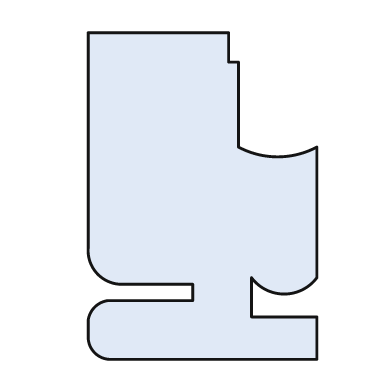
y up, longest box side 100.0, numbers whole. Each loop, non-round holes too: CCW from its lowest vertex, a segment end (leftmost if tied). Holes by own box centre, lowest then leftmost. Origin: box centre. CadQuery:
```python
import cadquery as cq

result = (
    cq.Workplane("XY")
    .moveTo(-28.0, -50.0)
    .lineTo(35.0, -50.0)
    .lineTo(35.0, -37.0)
    .lineTo(15.0, -37.0)
    .lineTo(15.0, -25.0)
    .threePointArc((25.0, -30.0), (35.0, -25.0))
    .lineTo(35.0, 15.0)
    .threePointArc((23.0, 12.0), (11.0, 15.0))
    .lineTo(11.0, 41.0)
    .lineTo(8.0, 41.0)
    .lineTo(8.0, 50.0)
    .lineTo(-35.0, 50.0)
    .lineTo(-35.0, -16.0)
    .threePointArc((-32.0, -24.0), (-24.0, -27.0))
    .lineTo(-3.0, -27.0)
    .lineTo(-3.0, -32.0)
    .lineTo(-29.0, -32.0)
    .threePointArc((-33.0, -34.0), (-35.0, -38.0))
    .lineTo(-35.0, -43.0)
    .threePointArc((-33.0, -48.0), (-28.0, -50.0))
    .close()
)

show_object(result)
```